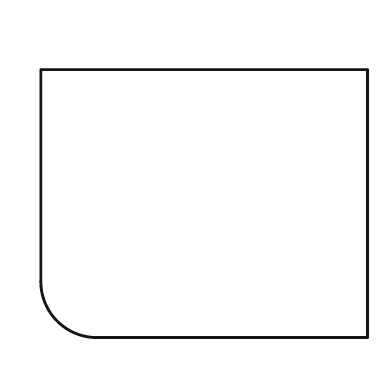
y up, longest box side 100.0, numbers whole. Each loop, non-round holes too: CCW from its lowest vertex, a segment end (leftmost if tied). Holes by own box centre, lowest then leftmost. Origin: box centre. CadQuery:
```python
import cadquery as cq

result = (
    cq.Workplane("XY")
    .moveTo(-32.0, -41.0)
    .lineTo(50.0, -41.0)
    .lineTo(50.0, 41.0)
    .lineTo(-50.0, 41.0)
    .lineTo(-50.0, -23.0)
    .threePointArc((-45.0, -36.0), (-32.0, -41.0))
    .close()
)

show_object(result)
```